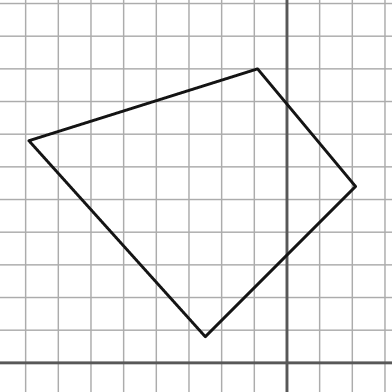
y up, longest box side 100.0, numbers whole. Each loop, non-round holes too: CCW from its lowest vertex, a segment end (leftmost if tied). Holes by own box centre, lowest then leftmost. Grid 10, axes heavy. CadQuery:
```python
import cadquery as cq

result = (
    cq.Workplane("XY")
    .moveTo(-25.0, 8.0)
    .lineTo(21.0, 54.0)
    .lineTo(-9.0, 90.0)
    .lineTo(-79.0, 68.0)
    .close()
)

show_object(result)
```